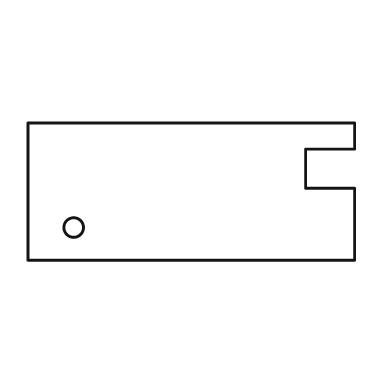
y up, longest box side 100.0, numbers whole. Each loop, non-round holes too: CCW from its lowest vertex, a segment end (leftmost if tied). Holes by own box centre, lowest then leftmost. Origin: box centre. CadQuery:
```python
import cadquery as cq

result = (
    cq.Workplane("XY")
    .moveTo(-50.0, -21.0)
    .lineTo(50.0, -21.0)
    .lineTo(50.0, 1.0)
    .lineTo(35.0, 1.0)
    .lineTo(35.0, 13.0)
    .lineTo(50.0, 13.0)
    .lineTo(50.0, 21.0)
    .lineTo(-50.0, 21.0)
    .close()
    .moveTo(-36.0, -11.0)
    .circle(3.0)
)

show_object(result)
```